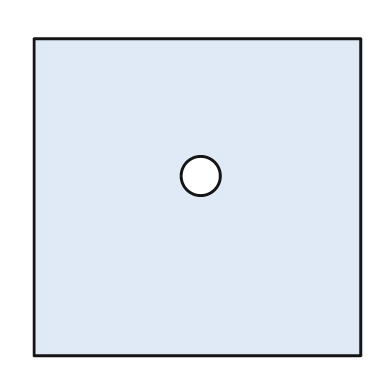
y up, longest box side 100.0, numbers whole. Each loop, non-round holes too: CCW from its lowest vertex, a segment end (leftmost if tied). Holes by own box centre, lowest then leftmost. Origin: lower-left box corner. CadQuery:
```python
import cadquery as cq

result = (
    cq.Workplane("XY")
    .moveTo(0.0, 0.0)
    .lineTo(100.0, 0.0)
    .lineTo(100.0, 97.0)
    .lineTo(0.0, 97.0)
    .close()
    .moveTo(51.0, 55.0)
    .circle(6.0)
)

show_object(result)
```